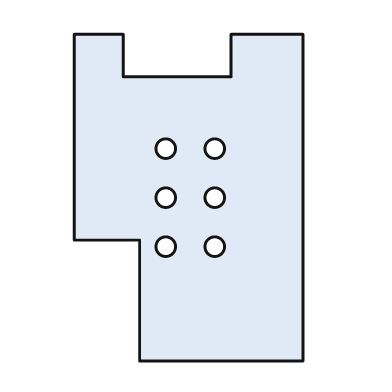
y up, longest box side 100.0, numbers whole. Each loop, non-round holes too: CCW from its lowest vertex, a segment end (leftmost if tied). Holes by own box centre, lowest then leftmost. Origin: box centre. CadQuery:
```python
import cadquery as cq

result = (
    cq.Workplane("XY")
    .moveTo(-15.0, -50.0)
    .lineTo(35.0, -50.0)
    .lineTo(35.0, 50.0)
    .lineTo(13.0, 50.0)
    .lineTo(13.0, 37.0)
    .lineTo(-20.0, 37.0)
    .lineTo(-20.0, 50.0)
    .lineTo(-35.0, 50.0)
    .lineTo(-35.0, -13.0)
    .lineTo(-15.0, -13.0)
    .close()
    .moveTo(-7.0, -15.0)
    .circle(3.0)
    .moveTo(8.0, -15.0)
    .circle(3.0)
    .moveTo(-7.0, 0.0)
    .circle(3.0)
    .moveTo(8.0, 0.0)
    .circle(3.0)
    .moveTo(-7.0, 15.0)
    .circle(3.0)
    .moveTo(8.0, 15.0)
    .circle(3.0)
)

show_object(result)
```